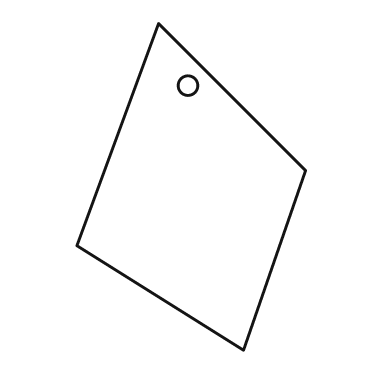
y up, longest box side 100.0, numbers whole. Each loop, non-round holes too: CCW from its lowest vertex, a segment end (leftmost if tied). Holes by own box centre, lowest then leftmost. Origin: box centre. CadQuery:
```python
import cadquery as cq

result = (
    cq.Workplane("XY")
    .moveTo(16.0, -50.0)
    .lineTo(35.0, 5.0)
    .lineTo(-10.0, 50.0)
    .lineTo(-35.0, -18.0)
    .close()
    .moveTo(-1.0, 31.0)
    .circle(3.0)
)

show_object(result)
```